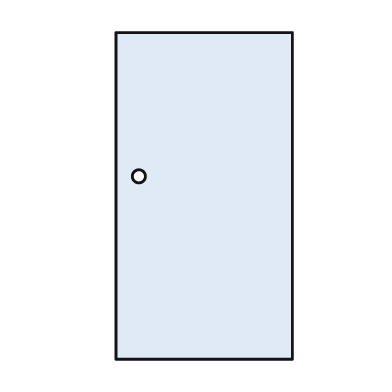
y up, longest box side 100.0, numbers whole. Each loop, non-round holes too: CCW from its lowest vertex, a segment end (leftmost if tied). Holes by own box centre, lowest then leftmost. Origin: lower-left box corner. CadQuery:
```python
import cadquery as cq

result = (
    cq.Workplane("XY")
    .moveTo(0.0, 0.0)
    .lineTo(54.0, 0.0)
    .lineTo(54.0, 100.0)
    .lineTo(0.0, 100.0)
    .close()
    .moveTo(7.0, 56.0)
    .circle(2.0)
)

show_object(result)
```